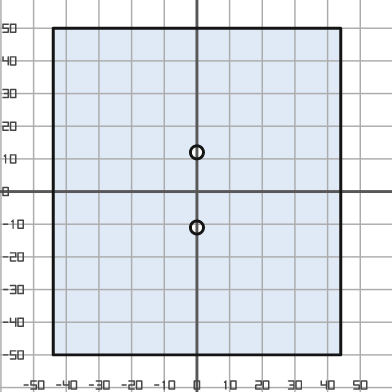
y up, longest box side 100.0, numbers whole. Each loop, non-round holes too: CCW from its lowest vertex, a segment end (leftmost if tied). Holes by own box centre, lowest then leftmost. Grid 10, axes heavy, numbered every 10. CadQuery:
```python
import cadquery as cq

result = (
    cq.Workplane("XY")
    .moveTo(-44.0, -50.0)
    .lineTo(44.0, -50.0)
    .lineTo(44.0, 50.0)
    .lineTo(-44.0, 50.0)
    .close()
    .moveTo(0.0, -11.0)
    .circle(2.0)
    .moveTo(0.0, 12.0)
    .circle(2.0)
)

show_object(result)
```